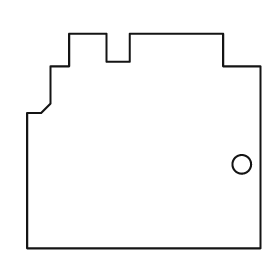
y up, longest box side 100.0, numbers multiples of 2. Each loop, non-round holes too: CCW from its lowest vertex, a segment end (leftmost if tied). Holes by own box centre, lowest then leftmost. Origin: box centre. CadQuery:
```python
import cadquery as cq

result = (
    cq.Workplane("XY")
    .moveTo(-50.0, -46.0)
    .lineTo(50.0, -46.0)
    .lineTo(50.0, 32.0)
    .lineTo(34.0, 32.0)
    .lineTo(34.0, 46.0)
    .lineTo(-6.0, 46.0)
    .lineTo(-6.0, 34.0)
    .lineTo(-16.0, 34.0)
    .lineTo(-16.0, 46.0)
    .lineTo(-32.0, 46.0)
    .lineTo(-32.0, 32.0)
    .lineTo(-40.0, 32.0)
    .lineTo(-40.0, 16.0)
    .lineTo(-44.0, 12.0)
    .lineTo(-50.0, 12.0)
    .close()
    .moveTo(42.0, -10.0)
    .circle(4.0)
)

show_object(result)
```